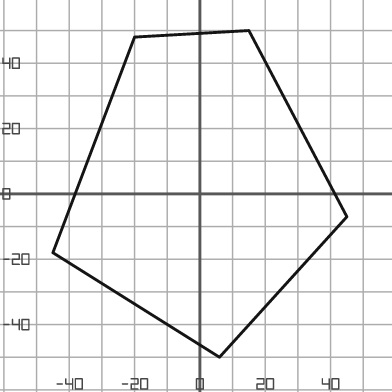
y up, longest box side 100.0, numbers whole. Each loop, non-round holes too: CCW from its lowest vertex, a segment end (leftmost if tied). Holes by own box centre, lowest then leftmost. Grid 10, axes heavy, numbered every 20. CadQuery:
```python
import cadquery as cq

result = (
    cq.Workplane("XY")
    .moveTo(6.0, -50.0)
    .lineTo(45.0, -7.0)
    .lineTo(15.0, 50.0)
    .lineTo(-20.0, 48.0)
    .lineTo(-45.0, -18.0)
    .close()
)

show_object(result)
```